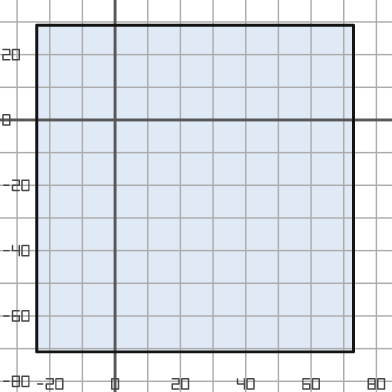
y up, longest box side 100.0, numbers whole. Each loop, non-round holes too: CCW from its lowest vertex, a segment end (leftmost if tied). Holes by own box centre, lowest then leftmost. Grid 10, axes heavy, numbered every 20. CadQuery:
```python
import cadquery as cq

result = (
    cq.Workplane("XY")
    .moveTo(-24.0, -71.0)
    .lineTo(73.0, -71.0)
    .lineTo(73.0, 29.0)
    .lineTo(-24.0, 29.0)
    .close()
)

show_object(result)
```